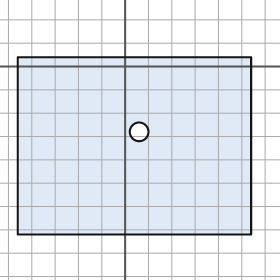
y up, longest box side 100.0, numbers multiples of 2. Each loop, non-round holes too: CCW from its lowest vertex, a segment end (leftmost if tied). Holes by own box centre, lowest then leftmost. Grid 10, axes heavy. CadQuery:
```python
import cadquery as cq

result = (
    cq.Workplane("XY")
    .moveTo(-46.0, -72.0)
    .lineTo(54.0, -72.0)
    .lineTo(54.0, 4.0)
    .lineTo(-46.0, 4.0)
    .close()
    .moveTo(6.0, -28.0)
    .circle(4.0)
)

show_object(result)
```